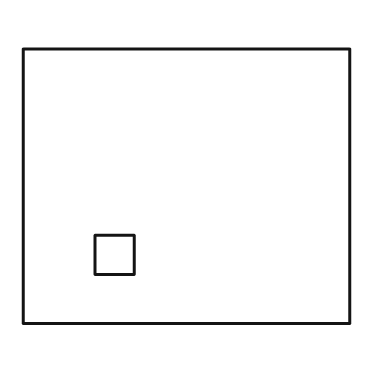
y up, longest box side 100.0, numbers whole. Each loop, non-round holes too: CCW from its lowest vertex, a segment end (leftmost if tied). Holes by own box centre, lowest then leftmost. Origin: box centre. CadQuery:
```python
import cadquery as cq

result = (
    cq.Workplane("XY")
    .moveTo(-50.0, -42.0)
    .lineTo(50.0, -42.0)
    .lineTo(50.0, 42.0)
    .lineTo(-50.0, 42.0)
    .close()
    .moveTo(-28.0, -27.0)
    .lineTo(-16.0, -27.0)
    .lineTo(-16.0, -15.0)
    .lineTo(-28.0, -15.0)
    .close()
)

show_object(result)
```